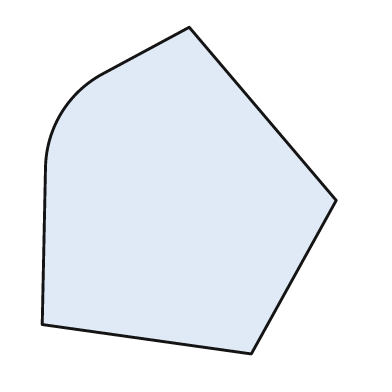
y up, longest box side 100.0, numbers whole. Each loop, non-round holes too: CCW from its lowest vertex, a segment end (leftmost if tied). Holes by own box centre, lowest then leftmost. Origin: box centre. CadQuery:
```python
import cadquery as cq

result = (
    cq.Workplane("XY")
    .moveTo(19.0, -50.0)
    .lineTo(45.0, -3.0)
    .lineTo(0.0, 50.0)
    .lineTo(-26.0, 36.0)
    .threePointArc((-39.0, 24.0), (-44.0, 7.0))
    .lineTo(-45.0, -41.0)
    .close()
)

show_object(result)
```